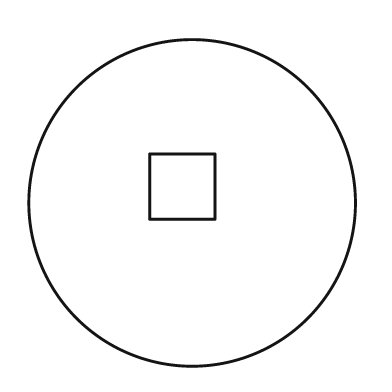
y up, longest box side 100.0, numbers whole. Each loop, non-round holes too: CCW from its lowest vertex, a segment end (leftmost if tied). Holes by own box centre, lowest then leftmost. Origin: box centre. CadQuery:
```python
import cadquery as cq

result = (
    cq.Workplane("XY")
    .moveTo(0.0, 0.0)
    .circle(50.0)
    .moveTo(-13.0, -5.0)
    .lineTo(7.0, -5.0)
    .lineTo(7.0, 15.0)
    .lineTo(-13.0, 15.0)
    .close()
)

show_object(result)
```